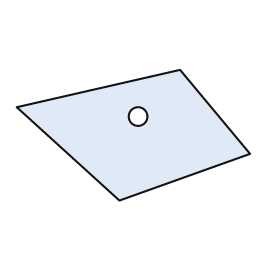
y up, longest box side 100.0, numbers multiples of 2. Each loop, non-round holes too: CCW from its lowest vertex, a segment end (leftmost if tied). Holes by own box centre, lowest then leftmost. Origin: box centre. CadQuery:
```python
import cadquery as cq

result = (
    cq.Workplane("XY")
    .moveTo(-6.0, -28.0)
    .lineTo(50.0, -8.0)
    .lineTo(20.0, 28.0)
    .lineTo(-50.0, 12.0)
    .close()
    .moveTo(2.0, 8.0)
    .circle(4.0)
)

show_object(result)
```